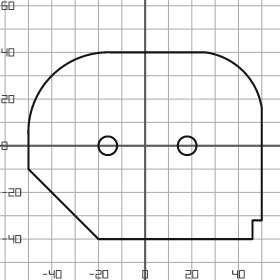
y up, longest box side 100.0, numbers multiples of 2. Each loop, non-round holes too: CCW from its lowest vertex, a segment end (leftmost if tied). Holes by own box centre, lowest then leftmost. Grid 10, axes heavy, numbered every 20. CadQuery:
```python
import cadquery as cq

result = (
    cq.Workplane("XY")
    .moveTo(-20.0, -40.0)
    .lineTo(46.0, -40.0)
    .lineTo(46.0, -32.0)
    .lineTo(50.0, -32.0)
    .lineTo(50.0, 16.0)
    .threePointArc((42.0, 32.0), (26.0, 40.0))
    .lineTo(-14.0, 40.0)
    .threePointArc((-40.0, 30.0), (-50.0, 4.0))
    .lineTo(-50.0, -10.0)
    .close()
    .moveTo(-16.0, 0.0)
    .circle(4.0)
    .moveTo(18.0, 0.0)
    .circle(4.0)
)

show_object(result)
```